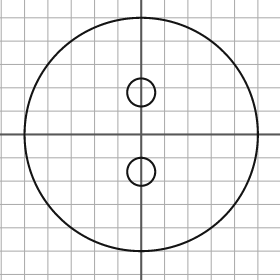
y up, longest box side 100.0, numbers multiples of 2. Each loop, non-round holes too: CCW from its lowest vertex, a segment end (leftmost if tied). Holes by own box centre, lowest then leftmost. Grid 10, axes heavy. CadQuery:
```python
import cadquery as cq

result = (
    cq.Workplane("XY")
    .moveTo(0.0, 0.0)
    .circle(50.0)
    .moveTo(0.0, -16.0)
    .circle(6.0)
    .moveTo(0.0, 18.0)
    .circle(6.0)
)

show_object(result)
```